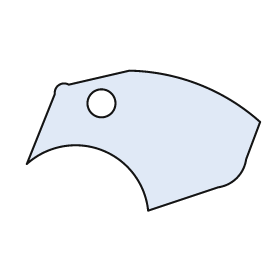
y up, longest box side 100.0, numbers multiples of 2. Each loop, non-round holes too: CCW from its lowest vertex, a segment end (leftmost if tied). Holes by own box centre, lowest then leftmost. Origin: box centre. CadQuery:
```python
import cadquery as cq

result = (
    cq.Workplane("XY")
    .moveTo(2.0, -30.0)
    .lineTo(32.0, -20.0)
    .threePointArc((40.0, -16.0), (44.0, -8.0))
    .lineTo(50.0, 8.0)
    .threePointArc((24.0, 24.0), (-6.0, 30.0))
    .lineTo(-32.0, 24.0)
    .threePointArc((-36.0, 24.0), (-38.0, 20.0))
    .lineTo(-50.0, -10.0)
    .threePointArc((-18.0, -4.0), (2.0, -30.0))
    .close()
    .moveTo(-18.0, 16.0)
    .circle(6.0)
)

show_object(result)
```